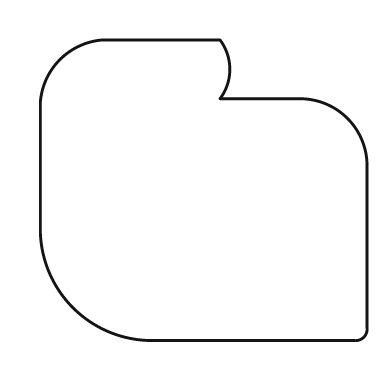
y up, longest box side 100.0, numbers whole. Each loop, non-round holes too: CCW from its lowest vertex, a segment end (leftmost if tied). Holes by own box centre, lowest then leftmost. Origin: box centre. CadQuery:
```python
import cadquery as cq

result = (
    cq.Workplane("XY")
    .moveTo(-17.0, -46.0)
    .lineTo(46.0, -46.0)
    .threePointArc((49.0, -45.0), (50.0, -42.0))
    .lineTo(50.0, 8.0)
    .threePointArc((44.0, 22.0), (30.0, 28.0))
    .lineTo(5.0, 28.0)
    .threePointArc((8.0, 37.0), (5.0, 46.0))
    .lineTo(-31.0, 46.0)
    .threePointArc((-44.0, 40.0), (-50.0, 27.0))
    .lineTo(-50.0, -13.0)
    .threePointArc((-40.0, -36.0), (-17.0, -46.0))
    .close()
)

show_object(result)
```